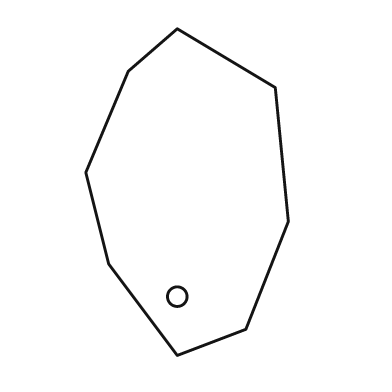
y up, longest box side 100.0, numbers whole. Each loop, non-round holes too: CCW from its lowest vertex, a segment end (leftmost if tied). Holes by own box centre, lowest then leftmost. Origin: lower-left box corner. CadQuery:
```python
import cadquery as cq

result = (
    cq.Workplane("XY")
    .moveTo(28.0, 0.0)
    .lineTo(49.0, 8.0)
    .lineTo(62.0, 41.0)
    .lineTo(58.0, 82.0)
    .lineTo(28.0, 100.0)
    .lineTo(13.0, 87.0)
    .lineTo(0.0, 56.0)
    .lineTo(7.0, 28.0)
    .close()
    .moveTo(28.0, 18.0)
    .circle(3.0)
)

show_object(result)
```